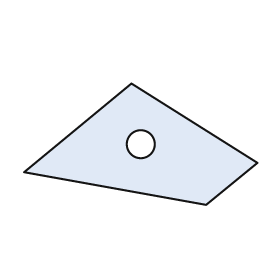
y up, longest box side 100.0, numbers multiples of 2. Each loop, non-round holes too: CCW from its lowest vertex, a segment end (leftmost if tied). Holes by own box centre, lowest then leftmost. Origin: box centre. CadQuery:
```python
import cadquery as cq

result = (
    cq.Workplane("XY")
    .moveTo(28.0, -26.0)
    .lineTo(50.0, -8.0)
    .lineTo(-4.0, 26.0)
    .lineTo(-50.0, -12.0)
    .close()
    .moveTo(0.0, 0.0)
    .circle(6.0)
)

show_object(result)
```